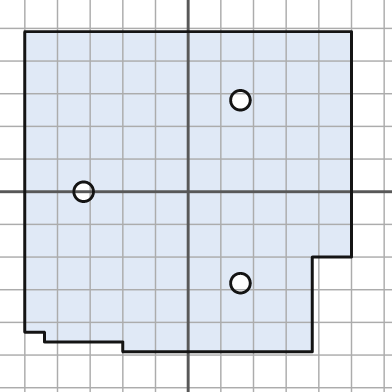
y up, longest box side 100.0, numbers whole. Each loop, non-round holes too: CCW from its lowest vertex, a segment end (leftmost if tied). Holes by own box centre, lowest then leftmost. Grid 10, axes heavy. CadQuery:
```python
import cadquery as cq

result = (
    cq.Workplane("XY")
    .moveTo(-20.0, -49.0)
    .lineTo(38.0, -49.0)
    .lineTo(38.0, -20.0)
    .lineTo(50.0, -20.0)
    .lineTo(50.0, 49.0)
    .lineTo(-50.0, 49.0)
    .lineTo(-50.0, -43.0)
    .lineTo(-44.0, -43.0)
    .lineTo(-44.0, -46.0)
    .lineTo(-20.0, -46.0)
    .close()
    .moveTo(16.0, -28.0)
    .circle(3.0)
    .moveTo(-32.0, 0.0)
    .circle(3.0)
    .moveTo(16.0, 28.0)
    .circle(3.0)
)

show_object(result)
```